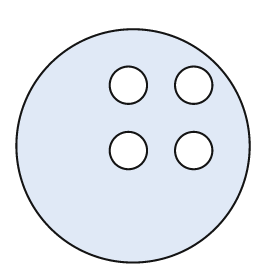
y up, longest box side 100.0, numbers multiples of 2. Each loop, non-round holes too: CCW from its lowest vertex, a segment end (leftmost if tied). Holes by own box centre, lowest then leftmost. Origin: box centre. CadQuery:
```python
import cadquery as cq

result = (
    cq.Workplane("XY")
    .moveTo(0.0, 0.0)
    .circle(50.0)
    .moveTo(-2.0, -2.0)
    .circle(8.0)
    .moveTo(26.0, -2.0)
    .circle(8.0)
    .moveTo(-2.0, 26.0)
    .circle(8.0)
    .moveTo(26.0, 26.0)
    .circle(8.0)
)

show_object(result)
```